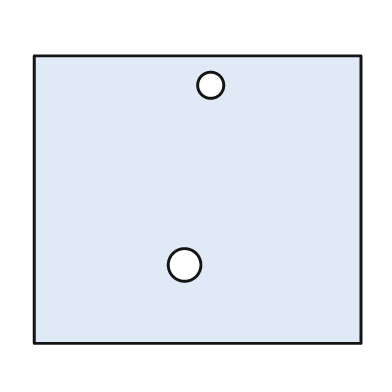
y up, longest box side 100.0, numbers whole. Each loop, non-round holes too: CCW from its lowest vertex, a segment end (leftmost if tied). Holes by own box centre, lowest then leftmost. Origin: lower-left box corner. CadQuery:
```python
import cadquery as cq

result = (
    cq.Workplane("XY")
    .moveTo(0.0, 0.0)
    .lineTo(100.0, 0.0)
    .lineTo(100.0, 88.0)
    .lineTo(0.0, 88.0)
    .close()
    .moveTo(46.0, 24.0)
    .circle(5.0)
    .moveTo(54.0, 79.0)
    .circle(4.0)
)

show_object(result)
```